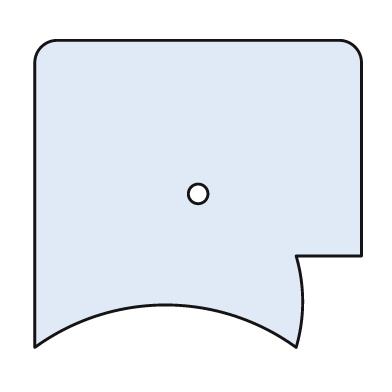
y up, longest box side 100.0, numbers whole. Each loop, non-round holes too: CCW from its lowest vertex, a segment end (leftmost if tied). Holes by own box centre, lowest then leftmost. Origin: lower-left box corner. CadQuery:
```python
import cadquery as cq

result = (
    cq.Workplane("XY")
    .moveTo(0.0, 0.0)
    .threePointArc((40.0, 13.0), (80.0, 0.0))
    .threePointArc((82.0, 14.0), (80.0, 28.0))
    .lineTo(100.0, 28.0)
    .lineTo(100.0, 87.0)
    .threePointArc((98.0, 92.0), (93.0, 94.0))
    .lineTo(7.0, 94.0)
    .threePointArc((2.0, 92.0), (0.0, 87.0))
    .close()
    .moveTo(50.0, 47.0)
    .circle(3.0)
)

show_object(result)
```